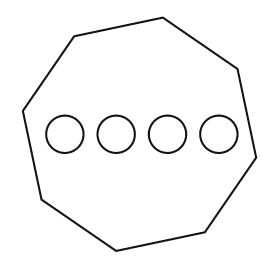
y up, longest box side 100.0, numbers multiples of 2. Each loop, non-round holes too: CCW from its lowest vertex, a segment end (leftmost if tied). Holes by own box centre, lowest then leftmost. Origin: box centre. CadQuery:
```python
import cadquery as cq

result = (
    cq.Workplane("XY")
    .moveTo(-10.0, -50.0)
    .lineTo(28.0, -42.0)
    .lineTo(50.0, -10.0)
    .lineTo(42.0, 28.0)
    .lineTo(10.0, 50.0)
    .lineTo(-28.0, 42.0)
    .lineTo(-50.0, 10.0)
    .lineTo(-42.0, -28.0)
    .close()
    .moveTo(-32.0, 0.0)
    .circle(8.0)
    .moveTo(-10.0, 0.0)
    .circle(8.0)
    .moveTo(12.0, 0.0)
    .circle(8.0)
    .moveTo(34.0, 0.0)
    .circle(8.0)
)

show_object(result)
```